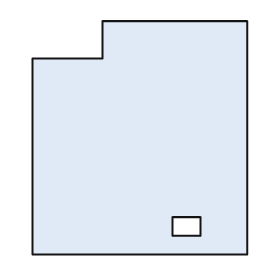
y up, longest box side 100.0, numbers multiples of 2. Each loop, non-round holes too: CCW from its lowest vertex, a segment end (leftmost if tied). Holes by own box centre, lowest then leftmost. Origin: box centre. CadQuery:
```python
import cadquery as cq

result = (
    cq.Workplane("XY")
    .moveTo(-46.0, -50.0)
    .lineTo(46.0, -50.0)
    .lineTo(46.0, 50.0)
    .lineTo(-16.0, 50.0)
    .lineTo(-16.0, 34.0)
    .lineTo(-46.0, 34.0)
    .close()
    .moveTo(14.0, -42.0)
    .lineTo(26.0, -42.0)
    .lineTo(26.0, -34.0)
    .lineTo(14.0, -34.0)
    .close()
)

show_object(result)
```